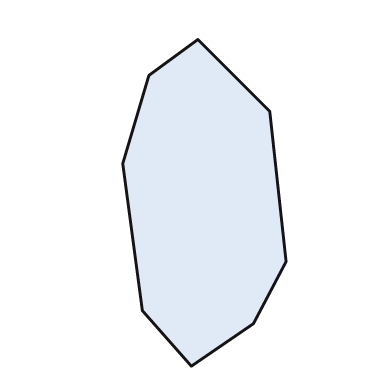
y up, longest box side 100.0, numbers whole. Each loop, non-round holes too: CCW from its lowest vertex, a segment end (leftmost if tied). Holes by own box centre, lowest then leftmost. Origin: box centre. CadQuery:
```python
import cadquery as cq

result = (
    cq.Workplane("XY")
    .moveTo(-4.0, -50.0)
    .lineTo(15.0, -37.0)
    .lineTo(25.0, -18.0)
    .lineTo(20.0, 28.0)
    .lineTo(-2.0, 50.0)
    .lineTo(-17.0, 39.0)
    .lineTo(-25.0, 12.0)
    .lineTo(-19.0, -33.0)
    .close()
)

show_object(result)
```